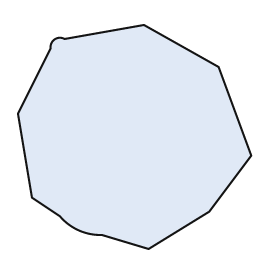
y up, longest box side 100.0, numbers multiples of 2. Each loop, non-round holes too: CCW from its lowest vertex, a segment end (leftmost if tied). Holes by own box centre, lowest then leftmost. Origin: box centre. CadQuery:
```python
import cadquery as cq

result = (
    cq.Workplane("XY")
    .moveTo(6.0, -48.0)
    .lineTo(32.0, -32.0)
    .lineTo(50.0, -8.0)
    .lineTo(36.0, 30.0)
    .lineTo(4.0, 48.0)
    .lineTo(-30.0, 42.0)
    .threePointArc((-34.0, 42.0), (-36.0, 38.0))
    .lineTo(-50.0, 10.0)
    .lineTo(-44.0, -26.0)
    .lineTo(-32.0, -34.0)
    .threePointArc((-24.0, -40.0), (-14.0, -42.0))
    .close()
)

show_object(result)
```